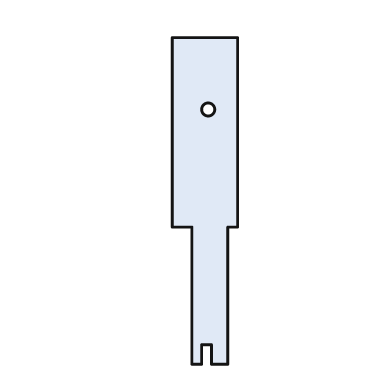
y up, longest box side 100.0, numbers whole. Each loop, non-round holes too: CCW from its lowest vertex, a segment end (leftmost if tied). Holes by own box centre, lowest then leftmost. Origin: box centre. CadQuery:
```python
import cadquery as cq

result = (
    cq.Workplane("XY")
    .moveTo(-4.0, -50.0)
    .lineTo(-1.0, -50.0)
    .lineTo(-1.0, -44.0)
    .lineTo(2.0, -44.0)
    .lineTo(2.0, -50.0)
    .lineTo(7.0, -50.0)
    .lineTo(7.0, -8.0)
    .lineTo(10.0, -8.0)
    .lineTo(10.0, 50.0)
    .lineTo(-10.0, 50.0)
    .lineTo(-10.0, -8.0)
    .lineTo(-4.0, -8.0)
    .close()
    .moveTo(1.0, 28.0)
    .circle(2.0)
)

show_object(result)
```